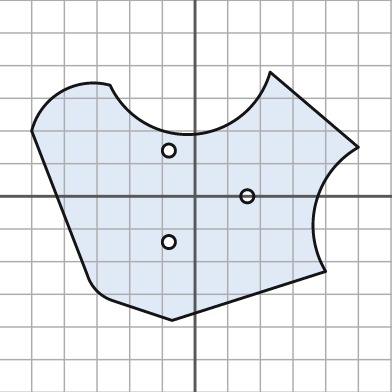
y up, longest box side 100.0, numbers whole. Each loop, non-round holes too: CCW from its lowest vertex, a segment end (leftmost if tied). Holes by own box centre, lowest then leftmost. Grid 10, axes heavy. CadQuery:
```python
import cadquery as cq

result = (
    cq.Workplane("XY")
    .moveTo(-7.0, -38.0)
    .lineTo(40.0, -23.0)
    .threePointArc((37.0, -2.0), (50.0, 15.0))
    .lineTo(23.0, 38.0)
    .threePointArc((0.0, 19.0), (-26.0, 34.0))
    .threePointArc((-41.0, 32.0), (-50.0, 20.0))
    .lineTo(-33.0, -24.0)
    .threePointArc((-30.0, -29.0), (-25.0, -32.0))
    .close()
    .moveTo(-8.0, -14.0)
    .circle(2.0)
    .moveTo(16.0, 0.0)
    .circle(2.0)
    .moveTo(-8.0, 14.0)
    .circle(2.0)
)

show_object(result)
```